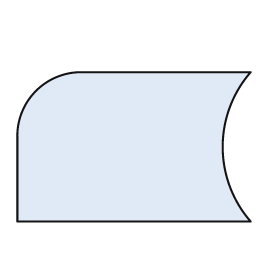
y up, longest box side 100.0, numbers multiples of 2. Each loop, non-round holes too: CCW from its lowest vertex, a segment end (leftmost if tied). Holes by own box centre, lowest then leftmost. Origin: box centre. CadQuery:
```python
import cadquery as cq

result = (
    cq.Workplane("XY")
    .moveTo(-50.0, -32.0)
    .lineTo(50.0, -32.0)
    .threePointArc((38.0, 0.0), (50.0, 32.0))
    .lineTo(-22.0, 32.0)
    .threePointArc((-42.0, 24.0), (-50.0, 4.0))
    .close()
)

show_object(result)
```